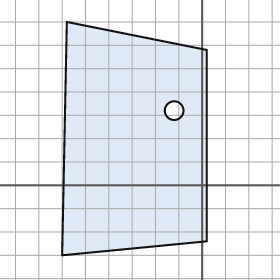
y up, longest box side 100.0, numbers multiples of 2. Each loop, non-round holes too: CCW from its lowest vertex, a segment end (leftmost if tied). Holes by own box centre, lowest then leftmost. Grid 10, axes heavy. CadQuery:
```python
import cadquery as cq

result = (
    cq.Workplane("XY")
    .moveTo(-60.0, -30.0)
    .lineTo(2.0, -24.0)
    .lineTo(2.0, 58.0)
    .lineTo(-58.0, 70.0)
    .close()
    .moveTo(-12.0, 32.0)
    .circle(4.0)
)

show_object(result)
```